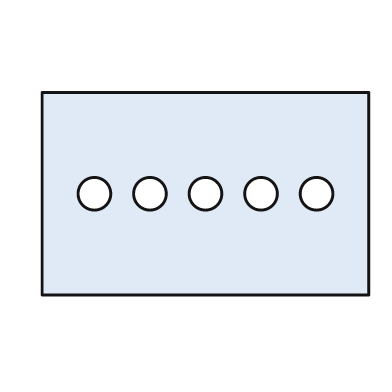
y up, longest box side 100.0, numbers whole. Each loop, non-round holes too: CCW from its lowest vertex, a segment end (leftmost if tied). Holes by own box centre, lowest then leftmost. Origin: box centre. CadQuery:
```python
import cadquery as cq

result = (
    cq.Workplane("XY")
    .moveTo(-50.0, -31.0)
    .lineTo(50.0, -31.0)
    .lineTo(50.0, 31.0)
    .lineTo(-50.0, 31.0)
    .close()
    .moveTo(-34.0, 0.0)
    .circle(5.0)
    .moveTo(-17.0, 0.0)
    .circle(5.0)
    .moveTo(0.0, 0.0)
    .circle(5.0)
    .moveTo(17.0, 0.0)
    .circle(5.0)
    .moveTo(34.0, 0.0)
    .circle(5.0)
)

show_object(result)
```